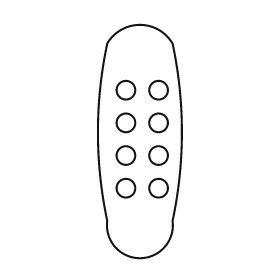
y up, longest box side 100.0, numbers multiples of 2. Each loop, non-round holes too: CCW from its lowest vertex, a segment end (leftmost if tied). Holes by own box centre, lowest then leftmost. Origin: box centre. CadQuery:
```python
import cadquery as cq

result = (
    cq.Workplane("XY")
    .moveTo(-14.0, -34.0)
    .threePointArc((0.0, -50.0), (14.0, -34.0))
    .threePointArc((18.0, 4.0), (14.0, 42.0))
    .threePointArc((0.0, 50.0), (-14.0, 42.0))
    .threePointArc((-18.0, 4.0), (-14.0, -34.0))
    .close()
    .moveTo(-6.0, -20.0)
    .circle(4.0)
    .moveTo(8.0, -20.0)
    .circle(4.0)
    .moveTo(-6.0, -6.0)
    .circle(4.0)
    .moveTo(8.0, -6.0)
    .circle(4.0)
    .moveTo(-6.0, 8.0)
    .circle(4.0)
    .moveTo(8.0, 8.0)
    .circle(4.0)
    .moveTo(-6.0, 22.0)
    .circle(4.0)
    .moveTo(8.0, 22.0)
    .circle(4.0)
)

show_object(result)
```